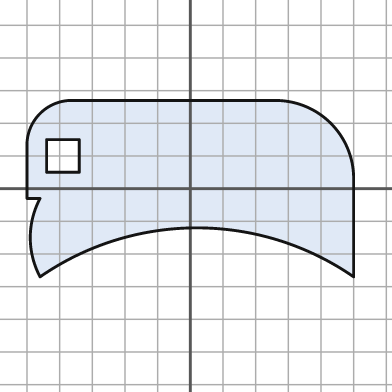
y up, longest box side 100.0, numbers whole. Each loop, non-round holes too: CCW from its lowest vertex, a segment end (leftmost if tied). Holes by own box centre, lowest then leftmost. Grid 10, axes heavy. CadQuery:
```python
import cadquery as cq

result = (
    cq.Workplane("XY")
    .moveTo(-46.0, -27.0)
    .threePointArc((2.0, -12.0), (50.0, -27.0))
    .lineTo(50.0, 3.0)
    .threePointArc((43.0, 20.0), (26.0, 27.0))
    .lineTo(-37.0, 27.0)
    .threePointArc((-46.0, 23.0), (-50.0, 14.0))
    .lineTo(-50.0, -3.0)
    .lineTo(-46.0, -3.0)
    .threePointArc((-49.0, -15.0), (-46.0, -27.0))
    .close()
    .moveTo(-44.0, 5.0)
    .lineTo(-34.0, 5.0)
    .lineTo(-34.0, 15.0)
    .lineTo(-44.0, 15.0)
    .close()
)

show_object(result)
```